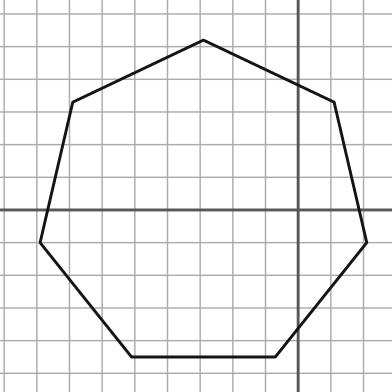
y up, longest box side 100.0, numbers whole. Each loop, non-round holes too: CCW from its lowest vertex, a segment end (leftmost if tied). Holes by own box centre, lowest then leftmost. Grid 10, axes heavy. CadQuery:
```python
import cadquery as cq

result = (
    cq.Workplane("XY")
    .moveTo(-51.0, -45.0)
    .lineTo(-7.0, -45.0)
    .lineTo(21.0, -10.0)
    .lineTo(11.0, 33.0)
    .lineTo(-29.0, 52.0)
    .lineTo(-69.0, 33.0)
    .lineTo(-79.0, -10.0)
    .close()
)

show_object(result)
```